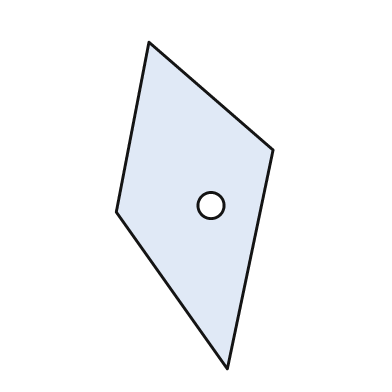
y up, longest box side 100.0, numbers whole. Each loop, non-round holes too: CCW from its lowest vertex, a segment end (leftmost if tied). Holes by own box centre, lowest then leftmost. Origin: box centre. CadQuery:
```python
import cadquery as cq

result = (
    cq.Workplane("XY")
    .moveTo(10.0, -50.0)
    .lineTo(24.0, 17.0)
    .lineTo(-14.0, 50.0)
    .lineTo(-24.0, -2.0)
    .close()
    .moveTo(5.0, 0.0)
    .circle(4.0)
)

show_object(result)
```